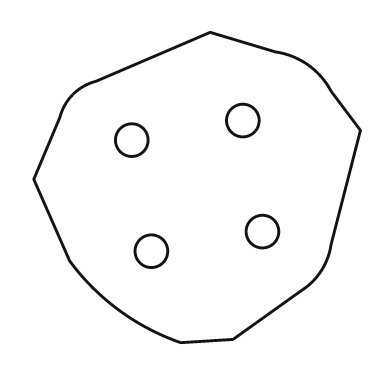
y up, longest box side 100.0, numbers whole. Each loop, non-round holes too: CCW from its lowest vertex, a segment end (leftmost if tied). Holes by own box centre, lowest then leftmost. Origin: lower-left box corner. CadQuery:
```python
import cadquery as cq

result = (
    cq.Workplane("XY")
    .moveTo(45.0, 0.0)
    .lineTo(61.0, 1.0)
    .lineTo(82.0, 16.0)
    .threePointArc((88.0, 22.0), (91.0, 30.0))
    .lineTo(100.0, 65.0)
    .lineTo(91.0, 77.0)
    .threePointArc((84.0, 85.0), (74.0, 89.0))
    .lineTo(54.0, 95.0)
    .lineTo(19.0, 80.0)
    .threePointArc((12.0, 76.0), (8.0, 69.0))
    .lineTo(0.0, 50.0)
    .lineTo(11.0, 25.0)
    .threePointArc((26.0, 10.0), (45.0, 0.0))
    .close()
    .moveTo(36.0, 28.0)
    .circle(5.0)
    .moveTo(70.0, 34.0)
    .circle(5.0)
    .moveTo(30.0, 62.0)
    .circle(5.0)
    .moveTo(64.0, 68.0)
    .circle(5.0)
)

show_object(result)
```